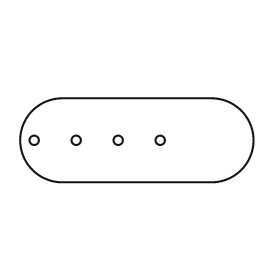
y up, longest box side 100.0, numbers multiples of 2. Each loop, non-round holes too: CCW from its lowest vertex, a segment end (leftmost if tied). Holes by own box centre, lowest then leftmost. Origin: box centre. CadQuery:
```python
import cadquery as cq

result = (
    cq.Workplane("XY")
    .moveTo(-32.0, -18.0)
    .lineTo(32.0, -18.0)
    .threePointArc((50.0, 0.0), (32.0, 18.0))
    .lineTo(-32.0, 18.0)
    .threePointArc((-50.0, 0.0), (-32.0, -18.0))
    .close()
    .moveTo(-44.0, 0.0)
    .circle(2.0)
    .moveTo(-26.0, 0.0)
    .circle(2.0)
    .moveTo(-8.0, 0.0)
    .circle(2.0)
    .moveTo(10.0, 0.0)
    .circle(2.0)
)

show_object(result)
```